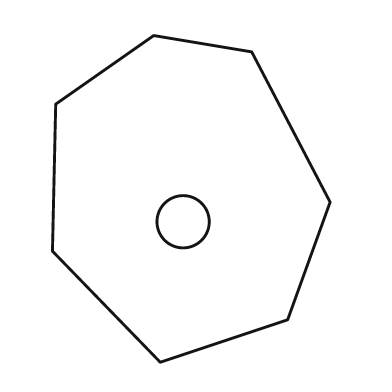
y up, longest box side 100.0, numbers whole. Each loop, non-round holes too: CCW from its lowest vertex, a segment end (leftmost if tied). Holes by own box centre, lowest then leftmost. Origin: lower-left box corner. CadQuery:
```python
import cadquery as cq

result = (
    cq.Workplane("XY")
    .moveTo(33.0, 0.0)
    .lineTo(72.0, 13.0)
    .lineTo(85.0, 49.0)
    .lineTo(61.0, 95.0)
    .lineTo(31.0, 100.0)
    .lineTo(1.0, 79.0)
    .lineTo(0.0, 34.0)
    .close()
    .moveTo(40.0, 43.0)
    .circle(8.0)
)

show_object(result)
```